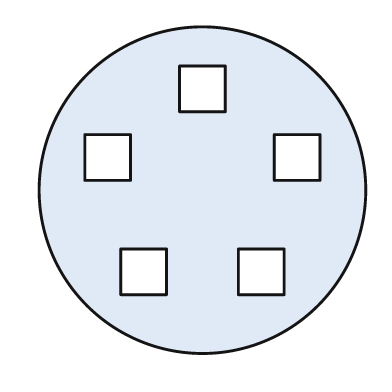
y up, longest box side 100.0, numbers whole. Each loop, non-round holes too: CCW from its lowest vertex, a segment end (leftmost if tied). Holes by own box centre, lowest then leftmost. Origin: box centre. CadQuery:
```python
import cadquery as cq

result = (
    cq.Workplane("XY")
    .moveTo(0.0, 0.0)
    .circle(50.0)
    .moveTo(-25.0, -32.0)
    .lineTo(-11.0, -32.0)
    .lineTo(-11.0, -18.0)
    .lineTo(-25.0, -18.0)
    .close()
    .moveTo(11.0, -32.0)
    .lineTo(25.0, -32.0)
    .lineTo(25.0, -18.0)
    .lineTo(11.0, -18.0)
    .close()
    .moveTo(-36.0, 3.0)
    .lineTo(-22.0, 3.0)
    .lineTo(-22.0, 17.0)
    .lineTo(-36.0, 17.0)
    .close()
    .moveTo(22.0, 3.0)
    .lineTo(36.0, 3.0)
    .lineTo(36.0, 17.0)
    .lineTo(22.0, 17.0)
    .close()
    .moveTo(-7.0, 24.0)
    .lineTo(7.0, 24.0)
    .lineTo(7.0, 38.0)
    .lineTo(-7.0, 38.0)
    .close()
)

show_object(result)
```